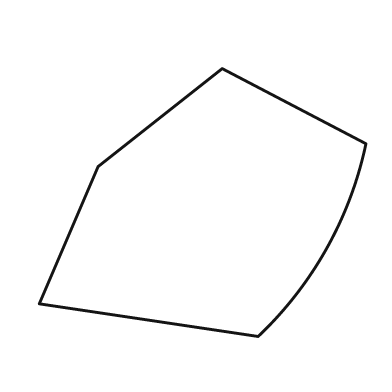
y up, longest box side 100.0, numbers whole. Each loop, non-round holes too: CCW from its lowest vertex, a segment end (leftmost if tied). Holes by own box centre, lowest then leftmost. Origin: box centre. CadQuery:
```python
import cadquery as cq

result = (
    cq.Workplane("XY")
    .moveTo(17.0, -41.0)
    .threePointArc((38.0, -14.0), (50.0, 18.0))
    .lineTo(6.0, 41.0)
    .lineTo(-32.0, 11.0)
    .lineTo(-50.0, -31.0)
    .close()
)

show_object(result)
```